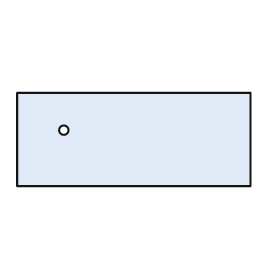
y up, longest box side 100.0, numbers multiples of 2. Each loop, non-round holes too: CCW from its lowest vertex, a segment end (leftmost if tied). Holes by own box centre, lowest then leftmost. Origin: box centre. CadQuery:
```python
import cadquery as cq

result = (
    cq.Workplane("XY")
    .moveTo(-50.0, -20.0)
    .lineTo(50.0, -20.0)
    .lineTo(50.0, 20.0)
    .lineTo(-50.0, 20.0)
    .close()
    .moveTo(-30.0, 4.0)
    .circle(2.0)
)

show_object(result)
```